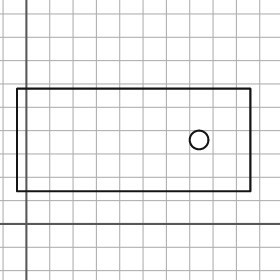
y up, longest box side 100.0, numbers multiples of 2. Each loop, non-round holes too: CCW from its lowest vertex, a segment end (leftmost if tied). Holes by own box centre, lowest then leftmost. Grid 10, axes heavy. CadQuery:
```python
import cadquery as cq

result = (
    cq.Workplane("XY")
    .moveTo(-4.0, 14.0)
    .lineTo(96.0, 14.0)
    .lineTo(96.0, 58.0)
    .lineTo(-4.0, 58.0)
    .close()
    .moveTo(74.0, 36.0)
    .circle(4.0)
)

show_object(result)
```